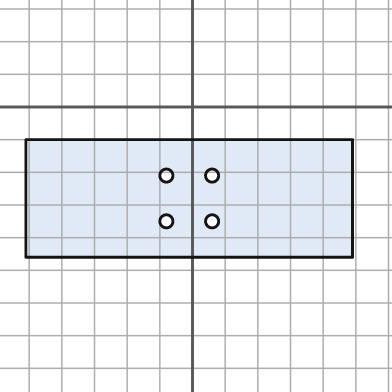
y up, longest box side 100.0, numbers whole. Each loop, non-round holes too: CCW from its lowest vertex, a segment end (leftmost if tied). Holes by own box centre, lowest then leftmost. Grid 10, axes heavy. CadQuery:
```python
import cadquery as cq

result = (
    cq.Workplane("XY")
    .moveTo(-51.0, -46.0)
    .lineTo(49.0, -46.0)
    .lineTo(49.0, -10.0)
    .lineTo(-51.0, -10.0)
    .close()
    .moveTo(-8.0, -35.0)
    .circle(2.0)
    .moveTo(6.0, -35.0)
    .circle(2.0)
    .moveTo(-8.0, -21.0)
    .circle(2.0)
    .moveTo(6.0, -21.0)
    .circle(2.0)
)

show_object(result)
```